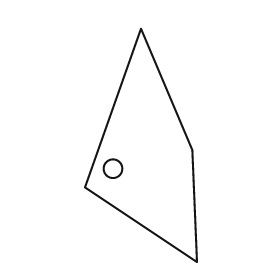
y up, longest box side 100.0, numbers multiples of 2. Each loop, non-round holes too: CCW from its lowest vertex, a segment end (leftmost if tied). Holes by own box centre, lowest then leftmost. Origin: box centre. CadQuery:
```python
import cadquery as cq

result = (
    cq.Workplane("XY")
    .moveTo(24.0, -50.0)
    .lineTo(22.0, -2.0)
    .lineTo(0.0, 50.0)
    .lineTo(-24.0, -18.0)
    .close()
    .moveTo(-12.0, -10.0)
    .circle(4.0)
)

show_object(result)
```